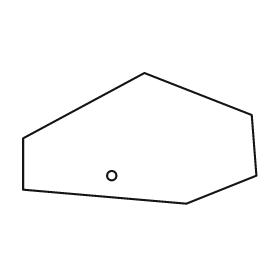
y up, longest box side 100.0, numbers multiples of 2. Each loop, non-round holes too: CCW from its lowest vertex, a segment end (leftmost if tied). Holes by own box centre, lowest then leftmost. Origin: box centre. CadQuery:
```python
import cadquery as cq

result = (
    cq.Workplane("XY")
    .moveTo(20.0, -28.0)
    .lineTo(50.0, -16.0)
    .lineTo(48.0, 10.0)
    .lineTo(2.0, 28.0)
    .lineTo(-50.0, 0.0)
    .lineTo(-50.0, -22.0)
    .close()
    .moveTo(-12.0, -16.0)
    .circle(2.0)
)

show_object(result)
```